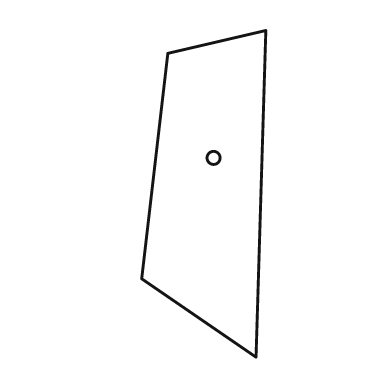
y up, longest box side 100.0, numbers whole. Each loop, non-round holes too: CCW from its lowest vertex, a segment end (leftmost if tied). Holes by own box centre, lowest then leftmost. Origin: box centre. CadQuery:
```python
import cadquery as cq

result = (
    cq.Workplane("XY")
    .moveTo(16.0, -50.0)
    .lineTo(19.0, 50.0)
    .lineTo(-11.0, 43.0)
    .lineTo(-19.0, -26.0)
    .close()
    .moveTo(3.0, 11.0)
    .circle(2.0)
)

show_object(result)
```